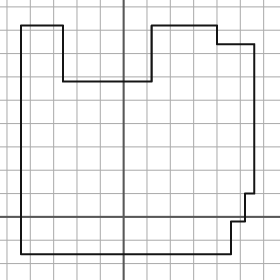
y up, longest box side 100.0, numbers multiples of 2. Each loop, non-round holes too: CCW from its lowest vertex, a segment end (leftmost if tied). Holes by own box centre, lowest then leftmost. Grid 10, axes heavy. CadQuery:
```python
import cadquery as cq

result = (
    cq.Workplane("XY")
    .moveTo(-44.0, -16.0)
    .lineTo(46.0, -16.0)
    .lineTo(46.0, -2.0)
    .lineTo(52.0, -2.0)
    .lineTo(52.0, 10.0)
    .lineTo(56.0, 10.0)
    .lineTo(56.0, 74.0)
    .lineTo(40.0, 74.0)
    .lineTo(40.0, 82.0)
    .lineTo(12.0, 82.0)
    .lineTo(12.0, 58.0)
    .lineTo(-26.0, 58.0)
    .lineTo(-26.0, 82.0)
    .lineTo(-44.0, 82.0)
    .close()
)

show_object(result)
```